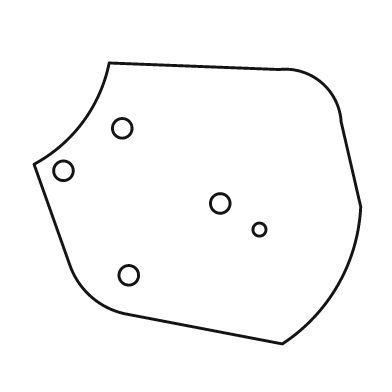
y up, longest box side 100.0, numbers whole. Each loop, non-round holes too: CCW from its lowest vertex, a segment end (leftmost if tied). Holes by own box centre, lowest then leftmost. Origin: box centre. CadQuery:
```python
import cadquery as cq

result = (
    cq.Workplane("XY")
    .moveTo(26.0, -43.0)
    .threePointArc((43.0, -25.0), (50.0, -1.0))
    .lineTo(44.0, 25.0)
    .threePointArc((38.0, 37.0), (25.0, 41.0))
    .lineTo(-27.0, 43.0)
    .threePointArc((-35.0, 25.0), (-50.0, 12.0))
    .lineTo(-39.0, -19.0)
    .threePointArc((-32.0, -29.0), (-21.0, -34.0))
    .close()
    .moveTo(-21.0, -22.0)
    .circle(3.0)
    .moveTo(19.0, -8.0)
    .circle(2.0)
    .moveTo(7.0, 0.0)
    .circle(3.0)
    .moveTo(-41.0, 10.0)
    .circle(3.0)
    .moveTo(-23.0, 23.0)
    .circle(3.0)
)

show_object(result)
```